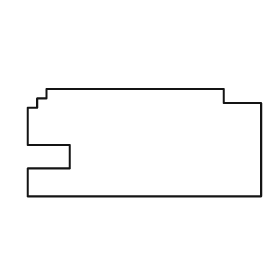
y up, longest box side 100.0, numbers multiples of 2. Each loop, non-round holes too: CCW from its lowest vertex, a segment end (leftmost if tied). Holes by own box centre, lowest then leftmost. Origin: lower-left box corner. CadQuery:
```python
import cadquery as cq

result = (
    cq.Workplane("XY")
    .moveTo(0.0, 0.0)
    .lineTo(100.0, 0.0)
    .lineTo(100.0, 40.0)
    .lineTo(84.0, 40.0)
    .lineTo(84.0, 46.0)
    .lineTo(8.0, 46.0)
    .lineTo(8.0, 42.0)
    .lineTo(4.0, 42.0)
    .lineTo(4.0, 38.0)
    .lineTo(0.0, 38.0)
    .lineTo(0.0, 22.0)
    .lineTo(18.0, 22.0)
    .lineTo(18.0, 12.0)
    .lineTo(0.0, 12.0)
    .close()
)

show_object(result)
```